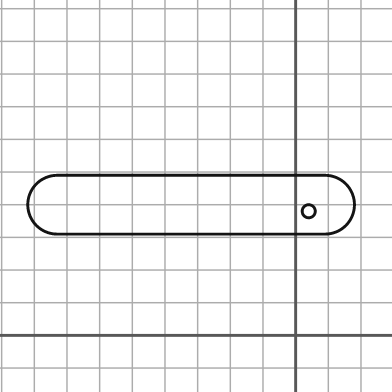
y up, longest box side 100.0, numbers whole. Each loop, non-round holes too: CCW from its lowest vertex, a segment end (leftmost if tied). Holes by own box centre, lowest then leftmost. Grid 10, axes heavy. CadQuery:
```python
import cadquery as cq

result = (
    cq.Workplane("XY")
    .moveTo(-73.0, 31.0)
    .lineTo(9.0, 31.0)
    .threePointArc((18.0, 40.0), (9.0, 49.0))
    .lineTo(-73.0, 49.0)
    .threePointArc((-82.0, 40.0), (-73.0, 31.0))
    .close()
    .moveTo(4.0, 38.0)
    .circle(2.0)
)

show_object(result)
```